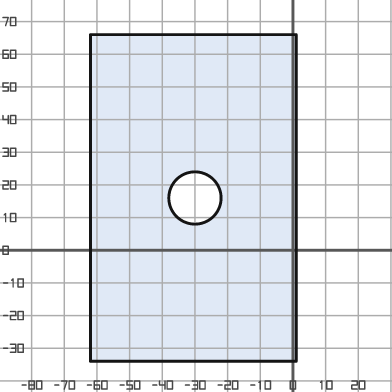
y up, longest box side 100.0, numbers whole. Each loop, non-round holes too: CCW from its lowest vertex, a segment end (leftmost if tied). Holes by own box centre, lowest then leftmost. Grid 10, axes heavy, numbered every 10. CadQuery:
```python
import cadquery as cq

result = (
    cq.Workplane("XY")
    .moveTo(-62.0, -34.0)
    .lineTo(1.0, -34.0)
    .lineTo(1.0, 66.0)
    .lineTo(-62.0, 66.0)
    .close()
    .moveTo(-30.0, 16.0)
    .circle(8.0)
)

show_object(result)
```